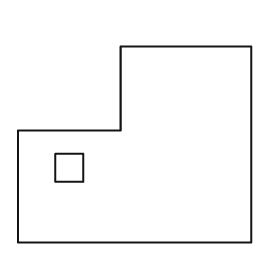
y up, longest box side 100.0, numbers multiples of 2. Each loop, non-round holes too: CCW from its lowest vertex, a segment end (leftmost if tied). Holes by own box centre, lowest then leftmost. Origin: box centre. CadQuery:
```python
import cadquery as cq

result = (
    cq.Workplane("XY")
    .moveTo(-50.0, -42.0)
    .lineTo(50.0, -42.0)
    .lineTo(50.0, 42.0)
    .lineTo(-6.0, 42.0)
    .lineTo(-6.0, 6.0)
    .lineTo(-50.0, 6.0)
    .close()
    .moveTo(-34.0, -16.0)
    .lineTo(-22.0, -16.0)
    .lineTo(-22.0, -4.0)
    .lineTo(-34.0, -4.0)
    .close()
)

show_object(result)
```